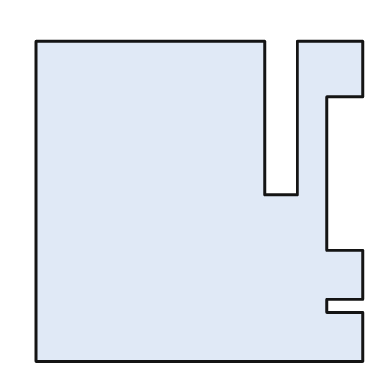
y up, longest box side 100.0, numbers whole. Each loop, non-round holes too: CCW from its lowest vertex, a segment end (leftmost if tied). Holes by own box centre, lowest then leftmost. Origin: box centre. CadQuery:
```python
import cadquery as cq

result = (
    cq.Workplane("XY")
    .moveTo(-50.0, -49.0)
    .lineTo(50.0, -49.0)
    .lineTo(50.0, -34.0)
    .lineTo(39.0, -34.0)
    .lineTo(39.0, -30.0)
    .lineTo(50.0, -30.0)
    .lineTo(50.0, -15.0)
    .lineTo(39.0, -15.0)
    .lineTo(39.0, 32.0)
    .lineTo(50.0, 32.0)
    .lineTo(50.0, 49.0)
    .lineTo(30.0, 49.0)
    .lineTo(30.0, 2.0)
    .lineTo(20.0, 2.0)
    .lineTo(20.0, 49.0)
    .lineTo(-50.0, 49.0)
    .close()
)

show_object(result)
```